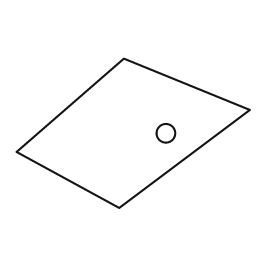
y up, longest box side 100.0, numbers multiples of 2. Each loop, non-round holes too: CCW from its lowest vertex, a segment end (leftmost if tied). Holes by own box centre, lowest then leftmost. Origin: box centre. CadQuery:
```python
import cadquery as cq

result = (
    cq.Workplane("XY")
    .moveTo(-6.0, -32.0)
    .lineTo(50.0, 10.0)
    .lineTo(-4.0, 32.0)
    .lineTo(-50.0, -8.0)
    .close()
    .moveTo(14.0, 0.0)
    .circle(4.0)
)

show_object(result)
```